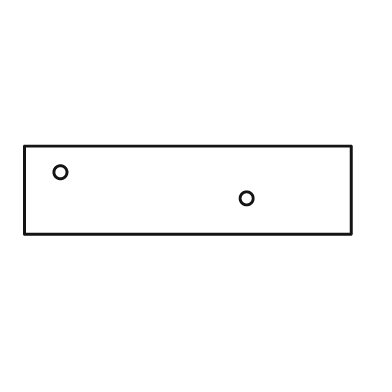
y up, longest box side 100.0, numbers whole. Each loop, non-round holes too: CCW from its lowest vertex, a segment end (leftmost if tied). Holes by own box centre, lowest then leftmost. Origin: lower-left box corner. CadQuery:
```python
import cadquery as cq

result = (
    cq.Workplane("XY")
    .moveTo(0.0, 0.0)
    .lineTo(100.0, 0.0)
    .lineTo(100.0, 27.0)
    .lineTo(0.0, 27.0)
    .close()
    .moveTo(68.0, 11.0)
    .circle(2.0)
    .moveTo(11.0, 19.0)
    .circle(2.0)
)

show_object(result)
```